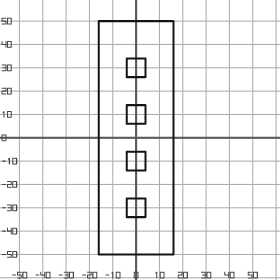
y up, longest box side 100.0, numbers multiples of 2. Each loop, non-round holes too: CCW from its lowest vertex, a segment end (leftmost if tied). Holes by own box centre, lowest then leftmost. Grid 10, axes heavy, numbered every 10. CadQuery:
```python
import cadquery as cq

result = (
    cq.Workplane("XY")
    .moveTo(-16.0, -50.0)
    .lineTo(16.0, -50.0)
    .lineTo(16.0, 50.0)
    .lineTo(-16.0, 50.0)
    .close()
    .moveTo(-4.0, -34.0)
    .lineTo(4.0, -34.0)
    .lineTo(4.0, -26.0)
    .lineTo(-4.0, -26.0)
    .close()
    .moveTo(-4.0, -14.0)
    .lineTo(4.0, -14.0)
    .lineTo(4.0, -6.0)
    .lineTo(-4.0, -6.0)
    .close()
    .moveTo(-4.0, 6.0)
    .lineTo(4.0, 6.0)
    .lineTo(4.0, 14.0)
    .lineTo(-4.0, 14.0)
    .close()
    .moveTo(-4.0, 26.0)
    .lineTo(4.0, 26.0)
    .lineTo(4.0, 34.0)
    .lineTo(-4.0, 34.0)
    .close()
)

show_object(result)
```